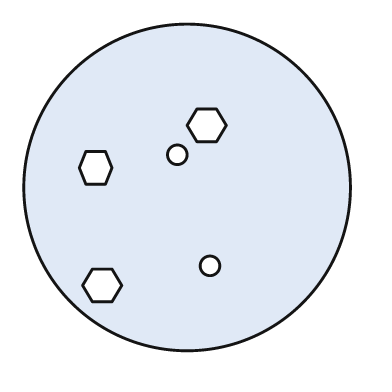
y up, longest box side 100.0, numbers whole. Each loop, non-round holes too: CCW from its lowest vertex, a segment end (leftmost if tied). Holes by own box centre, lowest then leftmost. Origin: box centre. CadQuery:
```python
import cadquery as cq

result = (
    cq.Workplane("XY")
    .moveTo(0.0, 0.0)
    .circle(50.0)
    .moveTo(-29.0, -35.0)
    .lineTo(-23.0, -35.0)
    .lineTo(-20.0, -30.0)
    .lineTo(-23.0, -25.0)
    .lineTo(-29.0, -25.0)
    .lineTo(-32.0, -30.0)
    .close()
    .moveTo(7.0, -24.0)
    .circle(3.0)
    .moveTo(-31.0, 1.0)
    .lineTo(-25.0, 1.0)
    .lineTo(-23.0, 6.0)
    .lineTo(-25.0, 11.0)
    .lineTo(-31.0, 11.0)
    .lineTo(-33.0, 6.0)
    .close()
    .moveTo(-3.0, 10.0)
    .circle(3.0)
    .moveTo(3.0, 14.0)
    .lineTo(9.0, 14.0)
    .lineTo(12.0, 19.0)
    .lineTo(9.0, 24.0)
    .lineTo(3.0, 24.0)
    .lineTo(0.0, 19.0)
    .close()
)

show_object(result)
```